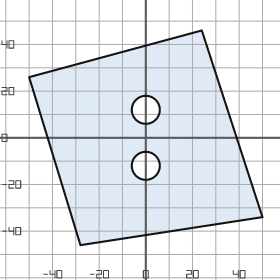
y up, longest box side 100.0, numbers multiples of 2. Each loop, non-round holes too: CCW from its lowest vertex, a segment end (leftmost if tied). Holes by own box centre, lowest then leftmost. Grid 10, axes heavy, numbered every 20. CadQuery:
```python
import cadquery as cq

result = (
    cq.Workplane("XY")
    .moveTo(-28.0, -46.0)
    .lineTo(50.0, -34.0)
    .lineTo(24.0, 46.0)
    .lineTo(-50.0, 26.0)
    .close()
    .moveTo(0.0, -12.0)
    .circle(6.0)
    .moveTo(0.0, 12.0)
    .circle(6.0)
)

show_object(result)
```